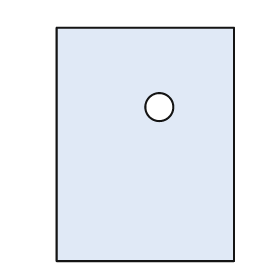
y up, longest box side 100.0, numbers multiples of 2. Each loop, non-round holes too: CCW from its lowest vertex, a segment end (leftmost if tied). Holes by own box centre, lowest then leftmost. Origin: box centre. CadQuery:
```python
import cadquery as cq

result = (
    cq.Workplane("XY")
    .moveTo(-38.0, -50.0)
    .lineTo(38.0, -50.0)
    .lineTo(38.0, 50.0)
    .lineTo(-38.0, 50.0)
    .close()
    .moveTo(6.0, 16.0)
    .circle(6.0)
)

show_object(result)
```